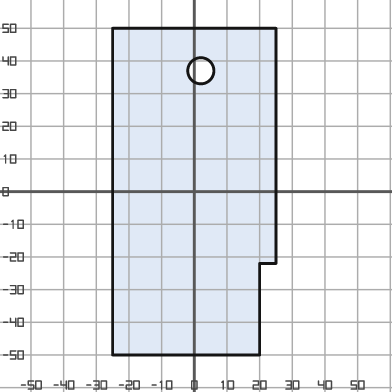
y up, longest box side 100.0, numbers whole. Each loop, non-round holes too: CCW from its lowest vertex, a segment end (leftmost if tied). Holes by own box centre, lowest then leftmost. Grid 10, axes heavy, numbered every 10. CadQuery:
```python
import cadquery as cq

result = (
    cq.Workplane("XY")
    .moveTo(-25.0, -50.0)
    .lineTo(20.0, -50.0)
    .lineTo(20.0, -22.0)
    .lineTo(25.0, -22.0)
    .lineTo(25.0, 50.0)
    .lineTo(-25.0, 50.0)
    .close()
    .moveTo(2.0, 37.0)
    .circle(4.0)
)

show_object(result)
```